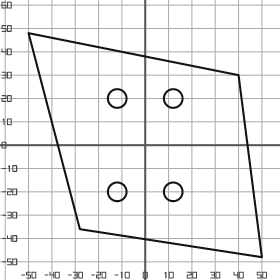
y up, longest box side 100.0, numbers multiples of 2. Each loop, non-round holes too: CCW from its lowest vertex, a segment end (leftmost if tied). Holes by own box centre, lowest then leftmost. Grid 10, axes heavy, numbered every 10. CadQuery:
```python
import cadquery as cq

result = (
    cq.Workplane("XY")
    .moveTo(50.0, -48.0)
    .lineTo(40.0, 30.0)
    .lineTo(-50.0, 48.0)
    .lineTo(-28.0, -36.0)
    .close()
    .moveTo(-12.0, -20.0)
    .circle(4.0)
    .moveTo(12.0, -20.0)
    .circle(4.0)
    .moveTo(-12.0, 20.0)
    .circle(4.0)
    .moveTo(12.0, 20.0)
    .circle(4.0)
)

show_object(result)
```